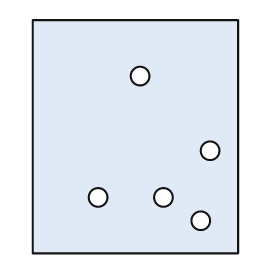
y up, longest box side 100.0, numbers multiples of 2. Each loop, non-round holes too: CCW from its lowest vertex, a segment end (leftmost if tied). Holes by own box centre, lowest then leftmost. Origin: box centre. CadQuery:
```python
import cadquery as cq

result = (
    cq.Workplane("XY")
    .moveTo(-44.0, -50.0)
    .lineTo(44.0, -50.0)
    .lineTo(44.0, 50.0)
    .lineTo(-44.0, 50.0)
    .close()
    .moveTo(28.0, -36.0)
    .circle(4.0)
    .moveTo(-16.0, -26.0)
    .circle(4.0)
    .moveTo(12.0, -26.0)
    .circle(4.0)
    .moveTo(32.0, -6.0)
    .circle(4.0)
    .moveTo(2.0, 26.0)
    .circle(4.0)
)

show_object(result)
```